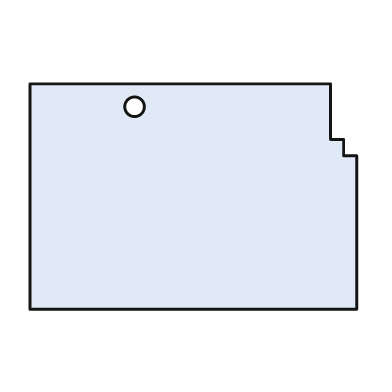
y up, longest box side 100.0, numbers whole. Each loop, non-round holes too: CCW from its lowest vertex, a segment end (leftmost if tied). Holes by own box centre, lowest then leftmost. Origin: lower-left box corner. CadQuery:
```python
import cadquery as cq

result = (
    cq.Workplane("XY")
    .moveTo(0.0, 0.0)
    .lineTo(100.0, 0.0)
    .lineTo(100.0, 47.0)
    .lineTo(96.0, 47.0)
    .lineTo(96.0, 52.0)
    .lineTo(92.0, 52.0)
    .lineTo(92.0, 69.0)
    .lineTo(0.0, 69.0)
    .close()
    .moveTo(32.0, 62.0)
    .circle(3.0)
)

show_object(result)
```